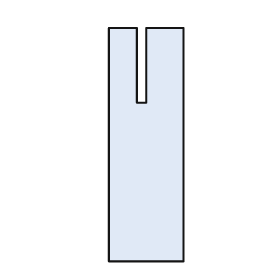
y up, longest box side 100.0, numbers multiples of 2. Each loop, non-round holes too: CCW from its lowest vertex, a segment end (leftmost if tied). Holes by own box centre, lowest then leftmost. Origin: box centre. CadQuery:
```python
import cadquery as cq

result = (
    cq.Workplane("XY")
    .moveTo(-16.0, -50.0)
    .lineTo(16.0, -50.0)
    .lineTo(16.0, 50.0)
    .lineTo(0.0, 50.0)
    .lineTo(0.0, 18.0)
    .lineTo(-4.0, 18.0)
    .lineTo(-4.0, 50.0)
    .lineTo(-16.0, 50.0)
    .close()
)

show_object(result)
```